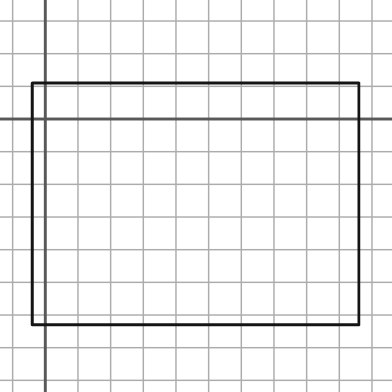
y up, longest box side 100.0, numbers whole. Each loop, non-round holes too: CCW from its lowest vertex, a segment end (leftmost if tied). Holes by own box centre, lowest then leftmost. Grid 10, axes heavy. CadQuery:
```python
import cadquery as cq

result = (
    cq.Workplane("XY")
    .moveTo(-4.0, -63.0)
    .lineTo(96.0, -63.0)
    .lineTo(96.0, 11.0)
    .lineTo(-4.0, 11.0)
    .close()
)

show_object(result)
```